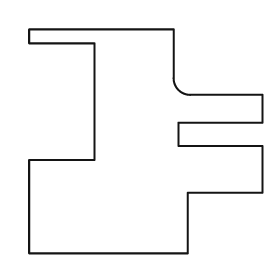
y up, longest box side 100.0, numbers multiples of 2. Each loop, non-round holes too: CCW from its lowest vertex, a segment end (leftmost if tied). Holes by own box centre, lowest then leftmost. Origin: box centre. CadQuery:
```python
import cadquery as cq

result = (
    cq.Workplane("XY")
    .moveTo(-50.0, -48.0)
    .lineTo(18.0, -48.0)
    .lineTo(18.0, -22.0)
    .lineTo(50.0, -22.0)
    .lineTo(50.0, -2.0)
    .lineTo(14.0, -2.0)
    .lineTo(14.0, 8.0)
    .lineTo(50.0, 8.0)
    .lineTo(50.0, 20.0)
    .lineTo(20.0, 20.0)
    .threePointArc((14.0, 22.0), (12.0, 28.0))
    .lineTo(12.0, 48.0)
    .lineTo(-50.0, 48.0)
    .lineTo(-50.0, 42.0)
    .lineTo(-22.0, 42.0)
    .lineTo(-22.0, -8.0)
    .lineTo(-50.0, -8.0)
    .close()
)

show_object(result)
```